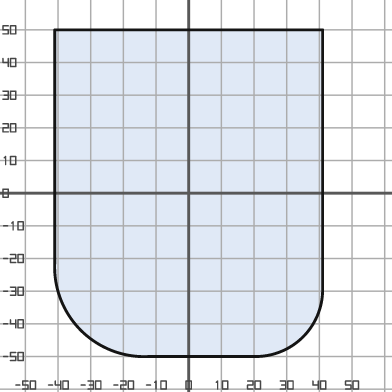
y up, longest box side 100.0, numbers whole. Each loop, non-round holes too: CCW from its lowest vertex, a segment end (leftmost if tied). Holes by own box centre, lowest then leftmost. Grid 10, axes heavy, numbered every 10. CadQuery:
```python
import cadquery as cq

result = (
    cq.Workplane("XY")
    .moveTo(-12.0, -50.0)
    .lineTo(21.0, -50.0)
    .threePointArc((35.0, -44.0), (41.0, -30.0))
    .lineTo(41.0, 50.0)
    .lineTo(-41.0, 50.0)
    .lineTo(-41.0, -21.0)
    .threePointArc((-33.0, -42.0), (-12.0, -50.0))
    .close()
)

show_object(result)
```